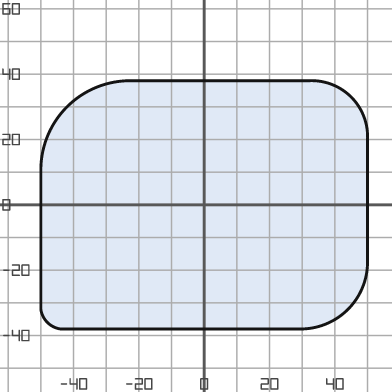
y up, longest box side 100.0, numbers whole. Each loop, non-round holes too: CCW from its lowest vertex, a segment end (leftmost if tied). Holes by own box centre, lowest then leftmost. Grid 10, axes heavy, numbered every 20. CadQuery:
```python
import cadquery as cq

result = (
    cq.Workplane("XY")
    .moveTo(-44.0, -38.0)
    .lineTo(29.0, -38.0)
    .threePointArc((44.0, -32.0), (50.0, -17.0))
    .lineTo(50.0, 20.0)
    .threePointArc((45.0, 33.0), (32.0, 38.0))
    .lineTo(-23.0, 38.0)
    .threePointArc((-42.0, 30.0), (-50.0, 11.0))
    .lineTo(-50.0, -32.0)
    .threePointArc((-48.0, -36.0), (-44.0, -38.0))
    .close()
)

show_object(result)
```